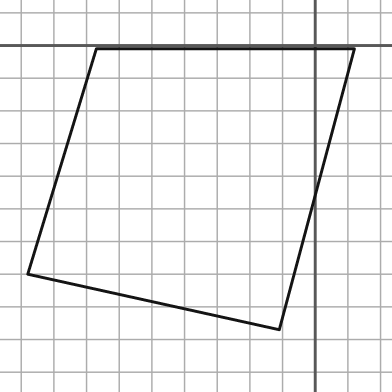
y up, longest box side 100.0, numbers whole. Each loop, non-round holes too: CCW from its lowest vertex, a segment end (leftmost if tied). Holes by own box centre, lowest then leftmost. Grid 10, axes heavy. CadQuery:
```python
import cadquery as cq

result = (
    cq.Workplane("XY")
    .moveTo(-11.0, -87.0)
    .lineTo(12.0, -1.0)
    .lineTo(-67.0, -1.0)
    .lineTo(-88.0, -70.0)
    .close()
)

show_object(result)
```